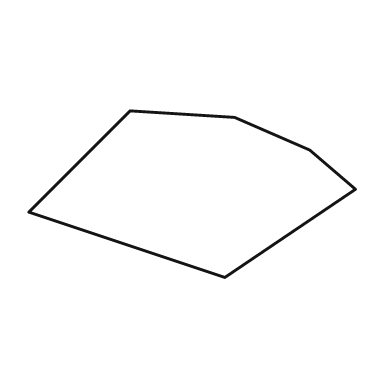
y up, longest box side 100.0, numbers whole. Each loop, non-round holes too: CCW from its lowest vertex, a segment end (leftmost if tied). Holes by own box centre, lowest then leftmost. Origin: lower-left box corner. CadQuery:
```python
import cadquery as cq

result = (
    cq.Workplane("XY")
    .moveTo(60.0, 0.0)
    .lineTo(100.0, 27.0)
    .lineTo(86.0, 39.0)
    .lineTo(63.0, 49.0)
    .lineTo(31.0, 51.0)
    .lineTo(0.0, 20.0)
    .close()
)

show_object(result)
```